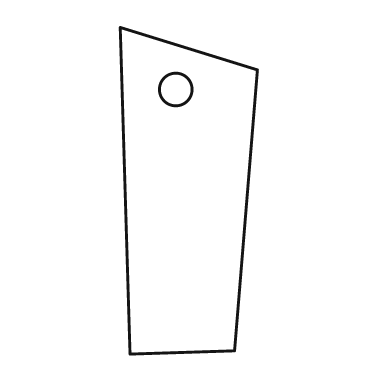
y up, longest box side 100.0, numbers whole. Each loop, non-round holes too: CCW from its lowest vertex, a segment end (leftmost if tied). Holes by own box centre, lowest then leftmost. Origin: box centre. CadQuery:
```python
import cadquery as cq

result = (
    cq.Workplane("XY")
    .moveTo(-18.0, -50.0)
    .lineTo(14.0, -49.0)
    .lineTo(21.0, 37.0)
    .lineTo(-21.0, 50.0)
    .close()
    .moveTo(-4.0, 31.0)
    .circle(5.0)
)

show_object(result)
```